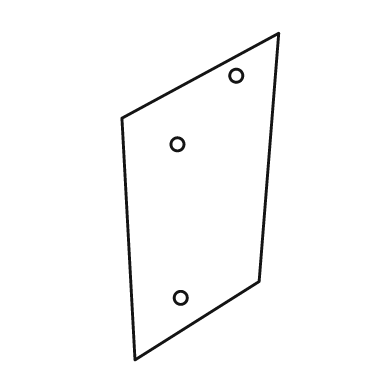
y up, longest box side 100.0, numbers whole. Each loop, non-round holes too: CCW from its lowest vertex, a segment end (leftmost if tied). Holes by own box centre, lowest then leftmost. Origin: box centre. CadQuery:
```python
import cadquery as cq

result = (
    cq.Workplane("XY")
    .moveTo(-20.0, -50.0)
    .lineTo(18.0, -26.0)
    .lineTo(24.0, 50.0)
    .lineTo(-24.0, 24.0)
    .close()
    .moveTo(-6.0, -31.0)
    .circle(2.0)
    .moveTo(-7.0, 16.0)
    .circle(2.0)
    .moveTo(11.0, 37.0)
    .circle(2.0)
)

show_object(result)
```